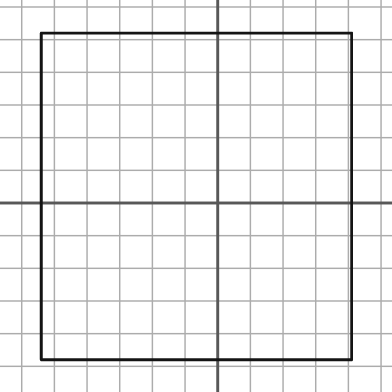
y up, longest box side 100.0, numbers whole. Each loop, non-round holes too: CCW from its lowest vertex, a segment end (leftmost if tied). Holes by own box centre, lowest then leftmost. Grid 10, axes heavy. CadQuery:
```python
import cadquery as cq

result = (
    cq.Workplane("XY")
    .moveTo(-54.0, -48.0)
    .lineTo(41.0, -48.0)
    .lineTo(41.0, 52.0)
    .lineTo(-54.0, 52.0)
    .close()
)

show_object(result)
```